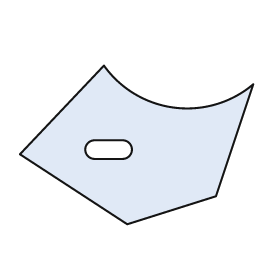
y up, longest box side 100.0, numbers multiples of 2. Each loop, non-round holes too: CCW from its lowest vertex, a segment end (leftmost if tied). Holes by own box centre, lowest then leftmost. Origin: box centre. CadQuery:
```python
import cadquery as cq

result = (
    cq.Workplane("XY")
    .moveTo(-4.0, -34.0)
    .lineTo(34.0, -22.0)
    .lineTo(50.0, 26.0)
    .threePointArc((16.0, 16.0), (-14.0, 34.0))
    .lineTo(-50.0, -4.0)
    .close()
    .moveTo(-18.0, -6.0)
    .lineTo(-6.0, -6.0)
    .threePointArc((-2.0, -2.0), (-6.0, 2.0))
    .lineTo(-18.0, 2.0)
    .threePointArc((-22.0, -2.0), (-18.0, -6.0))
    .close()
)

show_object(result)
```